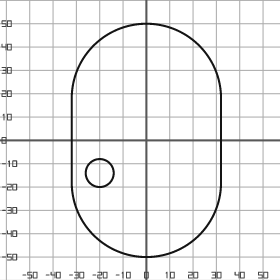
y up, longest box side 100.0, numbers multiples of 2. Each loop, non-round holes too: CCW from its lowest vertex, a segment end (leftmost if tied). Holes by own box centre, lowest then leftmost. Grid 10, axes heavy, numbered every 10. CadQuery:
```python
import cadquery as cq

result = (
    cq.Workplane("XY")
    .moveTo(-32.0, -18.0)
    .threePointArc((0.0, -50.0), (32.0, -18.0))
    .lineTo(32.0, 18.0)
    .threePointArc((0.0, 50.0), (-32.0, 18.0))
    .close()
    .moveTo(-20.0, -14.0)
    .circle(6.0)
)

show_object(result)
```